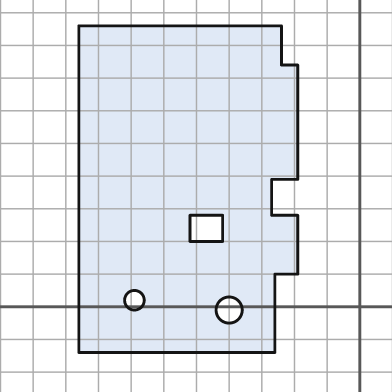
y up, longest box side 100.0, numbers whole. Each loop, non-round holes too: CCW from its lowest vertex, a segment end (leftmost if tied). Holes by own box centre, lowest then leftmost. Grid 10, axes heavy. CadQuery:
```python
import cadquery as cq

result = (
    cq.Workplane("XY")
    .moveTo(-86.0, -14.0)
    .lineTo(-26.0, -14.0)
    .lineTo(-26.0, 10.0)
    .lineTo(-19.0, 10.0)
    .lineTo(-19.0, 28.0)
    .lineTo(-27.0, 28.0)
    .lineTo(-27.0, 39.0)
    .lineTo(-19.0, 39.0)
    .lineTo(-19.0, 74.0)
    .lineTo(-24.0, 74.0)
    .lineTo(-24.0, 86.0)
    .lineTo(-86.0, 86.0)
    .close()
    .moveTo(-40.0, -1.0)
    .circle(4.0)
    .moveTo(-69.0, 2.0)
    .circle(3.0)
    .moveTo(-52.0, 20.0)
    .lineTo(-42.0, 20.0)
    .lineTo(-42.0, 28.0)
    .lineTo(-52.0, 28.0)
    .close()
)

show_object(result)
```